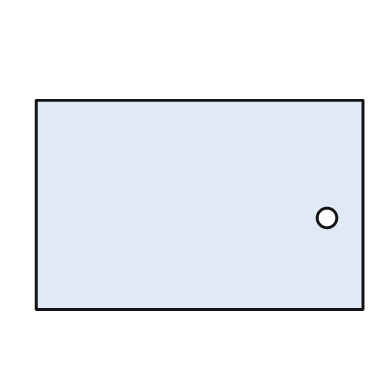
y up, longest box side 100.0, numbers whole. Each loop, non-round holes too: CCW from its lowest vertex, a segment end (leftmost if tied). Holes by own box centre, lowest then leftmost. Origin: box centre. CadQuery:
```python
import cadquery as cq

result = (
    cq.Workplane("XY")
    .moveTo(-50.0, -32.0)
    .lineTo(50.0, -32.0)
    .lineTo(50.0, 32.0)
    .lineTo(-50.0, 32.0)
    .close()
    .moveTo(39.0, -4.0)
    .circle(3.0)
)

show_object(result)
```